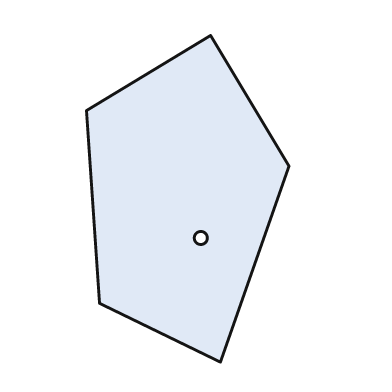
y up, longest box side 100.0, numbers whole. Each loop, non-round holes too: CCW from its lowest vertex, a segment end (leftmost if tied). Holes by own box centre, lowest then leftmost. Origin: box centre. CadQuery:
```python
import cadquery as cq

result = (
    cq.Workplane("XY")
    .moveTo(10.0, -50.0)
    .lineTo(31.0, 10.0)
    .lineTo(7.0, 50.0)
    .lineTo(-31.0, 27.0)
    .lineTo(-27.0, -32.0)
    .close()
    .moveTo(4.0, -12.0)
    .circle(2.0)
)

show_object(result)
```